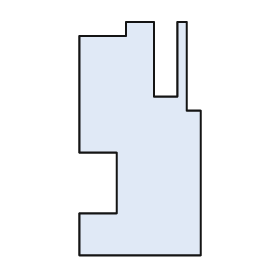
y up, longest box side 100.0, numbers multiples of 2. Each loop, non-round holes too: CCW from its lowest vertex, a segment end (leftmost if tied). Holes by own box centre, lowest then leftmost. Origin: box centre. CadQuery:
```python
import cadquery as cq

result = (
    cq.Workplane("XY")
    .moveTo(-26.0, -50.0)
    .lineTo(26.0, -50.0)
    .lineTo(26.0, 12.0)
    .lineTo(20.0, 12.0)
    .lineTo(20.0, 50.0)
    .lineTo(16.0, 50.0)
    .lineTo(16.0, 18.0)
    .lineTo(6.0, 18.0)
    .lineTo(6.0, 50.0)
    .lineTo(-6.0, 50.0)
    .lineTo(-6.0, 44.0)
    .lineTo(-26.0, 44.0)
    .lineTo(-26.0, -6.0)
    .lineTo(-10.0, -6.0)
    .lineTo(-10.0, -32.0)
    .lineTo(-26.0, -32.0)
    .close()
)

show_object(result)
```